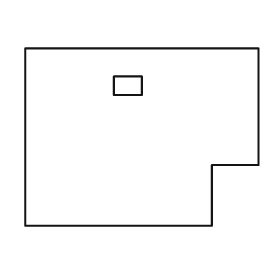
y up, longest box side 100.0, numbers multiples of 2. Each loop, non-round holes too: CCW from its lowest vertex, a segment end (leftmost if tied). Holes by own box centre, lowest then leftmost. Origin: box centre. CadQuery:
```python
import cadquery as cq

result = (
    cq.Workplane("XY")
    .moveTo(-50.0, -38.0)
    .lineTo(30.0, -38.0)
    .lineTo(30.0, -12.0)
    .lineTo(50.0, -12.0)
    .lineTo(50.0, 38.0)
    .lineTo(-50.0, 38.0)
    .close()
    .moveTo(-12.0, 18.0)
    .lineTo(0.0, 18.0)
    .lineTo(0.0, 26.0)
    .lineTo(-12.0, 26.0)
    .close()
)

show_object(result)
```